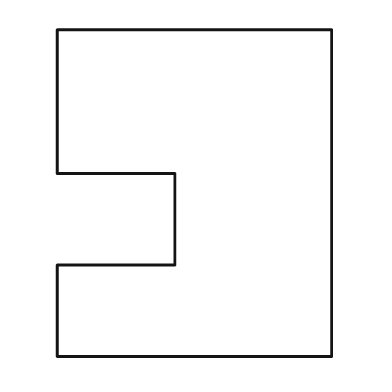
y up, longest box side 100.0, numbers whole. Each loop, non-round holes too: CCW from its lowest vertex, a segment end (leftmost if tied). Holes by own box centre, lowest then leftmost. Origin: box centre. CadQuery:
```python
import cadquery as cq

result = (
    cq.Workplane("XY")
    .moveTo(-42.0, -50.0)
    .lineTo(42.0, -50.0)
    .lineTo(42.0, 50.0)
    .lineTo(-42.0, 50.0)
    .lineTo(-42.0, 6.0)
    .lineTo(-6.0, 6.0)
    .lineTo(-6.0, -22.0)
    .lineTo(-42.0, -22.0)
    .close()
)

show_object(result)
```